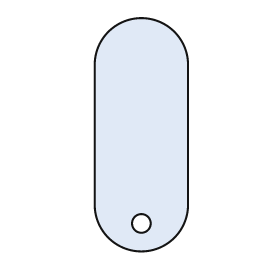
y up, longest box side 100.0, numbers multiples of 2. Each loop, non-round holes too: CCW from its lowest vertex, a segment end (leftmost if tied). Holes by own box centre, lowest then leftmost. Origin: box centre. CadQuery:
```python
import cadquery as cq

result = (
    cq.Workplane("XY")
    .moveTo(-20.0, -30.0)
    .threePointArc((0.0, -50.0), (20.0, -30.0))
    .lineTo(20.0, 30.0)
    .threePointArc((0.0, 50.0), (-20.0, 30.0))
    .close()
    .moveTo(0.0, -38.0)
    .circle(4.0)
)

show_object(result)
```